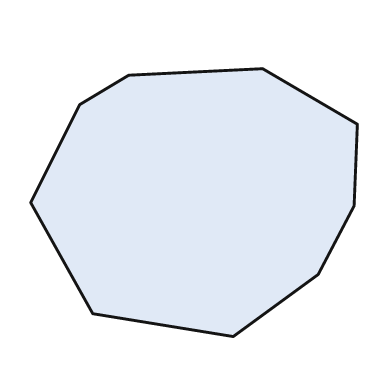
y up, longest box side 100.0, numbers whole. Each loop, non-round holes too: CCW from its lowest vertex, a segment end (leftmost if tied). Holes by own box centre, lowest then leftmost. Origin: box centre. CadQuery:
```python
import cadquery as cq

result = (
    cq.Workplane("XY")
    .moveTo(12.0, -41.0)
    .lineTo(38.0, -22.0)
    .lineTo(49.0, -1.0)
    .lineTo(50.0, 24.0)
    .lineTo(21.0, 41.0)
    .lineTo(-20.0, 39.0)
    .lineTo(-35.0, 30.0)
    .lineTo(-50.0, 0.0)
    .lineTo(-31.0, -34.0)
    .close()
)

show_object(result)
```